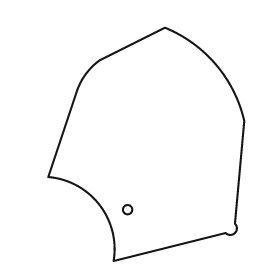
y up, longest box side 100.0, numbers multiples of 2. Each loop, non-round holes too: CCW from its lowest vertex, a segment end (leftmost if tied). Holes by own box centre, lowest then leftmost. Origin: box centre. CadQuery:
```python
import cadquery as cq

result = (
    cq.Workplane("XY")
    .moveTo(-14.0, -50.0)
    .lineTo(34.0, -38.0)
    .threePointArc((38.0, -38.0), (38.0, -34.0))
    .lineTo(42.0, 10.0)
    .threePointArc((30.0, 34.0), (8.0, 50.0))
    .lineTo(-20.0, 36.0)
    .threePointArc((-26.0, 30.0), (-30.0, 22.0))
    .lineTo(-42.0, -14.0)
    .threePointArc((-20.0, -26.0), (-14.0, -50.0))
    .close()
    .moveTo(-8.0, -28.0)
    .circle(2.0)
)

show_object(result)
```